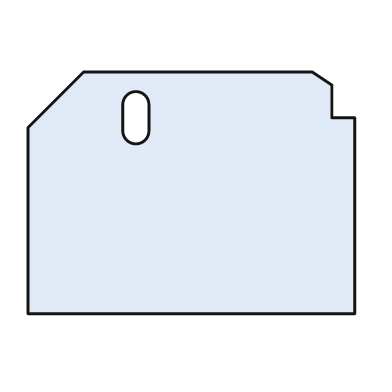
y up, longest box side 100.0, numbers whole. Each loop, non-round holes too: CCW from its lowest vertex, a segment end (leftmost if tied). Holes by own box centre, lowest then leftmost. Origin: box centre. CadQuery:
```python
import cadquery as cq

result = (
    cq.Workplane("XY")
    .moveTo(-50.0, -37.0)
    .lineTo(50.0, -37.0)
    .lineTo(50.0, 23.0)
    .lineTo(43.0, 23.0)
    .lineTo(43.0, 33.0)
    .lineTo(37.0, 37.0)
    .lineTo(-33.0, 37.0)
    .lineTo(-50.0, 20.0)
    .close()
    .moveTo(-21.0, 19.0)
    .threePointArc((-17.0, 15.0), (-13.0, 19.0))
    .lineTo(-13.0, 27.0)
    .threePointArc((-17.0, 31.0), (-21.0, 27.0))
    .close()
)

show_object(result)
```